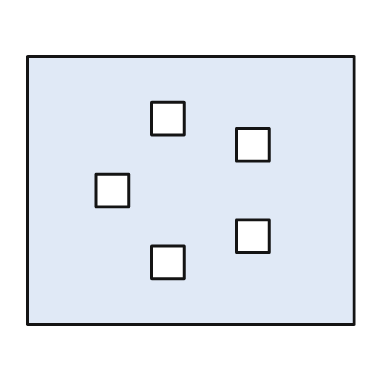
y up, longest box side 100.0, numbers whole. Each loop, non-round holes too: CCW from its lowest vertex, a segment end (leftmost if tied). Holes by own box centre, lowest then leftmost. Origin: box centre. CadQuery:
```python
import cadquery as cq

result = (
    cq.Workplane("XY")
    .moveTo(-50.0, -41.0)
    .lineTo(50.0, -41.0)
    .lineTo(50.0, 41.0)
    .lineTo(-50.0, 41.0)
    .close()
    .moveTo(-12.0, -27.0)
    .lineTo(-2.0, -27.0)
    .lineTo(-2.0, -17.0)
    .lineTo(-12.0, -17.0)
    .close()
    .moveTo(14.0, -19.0)
    .lineTo(24.0, -19.0)
    .lineTo(24.0, -9.0)
    .lineTo(14.0, -9.0)
    .close()
    .moveTo(-29.0, -5.0)
    .lineTo(-19.0, -5.0)
    .lineTo(-19.0, 5.0)
    .lineTo(-29.0, 5.0)
    .close()
    .moveTo(14.0, 9.0)
    .lineTo(24.0, 9.0)
    .lineTo(24.0, 19.0)
    .lineTo(14.0, 19.0)
    .close()
    .moveTo(-12.0, 17.0)
    .lineTo(-2.0, 17.0)
    .lineTo(-2.0, 27.0)
    .lineTo(-12.0, 27.0)
    .close()
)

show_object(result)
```